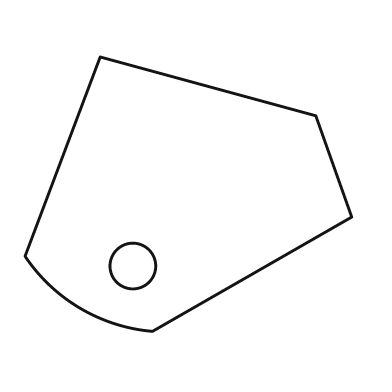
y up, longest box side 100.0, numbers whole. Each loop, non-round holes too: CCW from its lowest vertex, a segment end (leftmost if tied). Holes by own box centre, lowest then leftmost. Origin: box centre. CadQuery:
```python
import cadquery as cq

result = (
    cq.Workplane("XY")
    .moveTo(-11.0, -42.0)
    .lineTo(50.0, -7.0)
    .lineTo(39.0, 24.0)
    .lineTo(-27.0, 42.0)
    .lineTo(-50.0, -19.0)
    .threePointArc((-33.0, -35.0), (-11.0, -42.0))
    .close()
    .moveTo(-17.0, -22.0)
    .circle(7.0)
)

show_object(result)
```